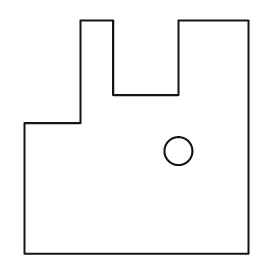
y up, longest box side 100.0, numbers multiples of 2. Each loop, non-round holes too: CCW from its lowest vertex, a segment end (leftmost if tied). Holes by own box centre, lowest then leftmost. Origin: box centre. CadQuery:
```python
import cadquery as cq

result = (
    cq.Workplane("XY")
    .moveTo(-48.0, -50.0)
    .lineTo(48.0, -50.0)
    .lineTo(48.0, 50.0)
    .lineTo(18.0, 50.0)
    .lineTo(18.0, 18.0)
    .lineTo(-10.0, 18.0)
    .lineTo(-10.0, 50.0)
    .lineTo(-24.0, 50.0)
    .lineTo(-24.0, 6.0)
    .lineTo(-48.0, 6.0)
    .close()
    .moveTo(18.0, -6.0)
    .circle(6.0)
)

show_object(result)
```